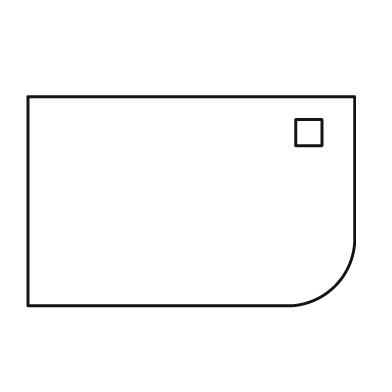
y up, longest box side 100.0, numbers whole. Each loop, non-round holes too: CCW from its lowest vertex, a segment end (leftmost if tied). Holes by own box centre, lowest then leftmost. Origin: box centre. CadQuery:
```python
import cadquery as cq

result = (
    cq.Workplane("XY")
    .moveTo(-50.0, -32.0)
    .lineTo(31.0, -32.0)
    .threePointArc((44.0, -26.0), (50.0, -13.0))
    .lineTo(50.0, 32.0)
    .lineTo(-50.0, 32.0)
    .close()
    .moveTo(32.0, 17.0)
    .lineTo(40.0, 17.0)
    .lineTo(40.0, 25.0)
    .lineTo(32.0, 25.0)
    .close()
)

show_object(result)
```